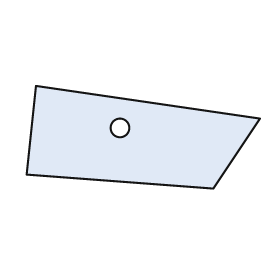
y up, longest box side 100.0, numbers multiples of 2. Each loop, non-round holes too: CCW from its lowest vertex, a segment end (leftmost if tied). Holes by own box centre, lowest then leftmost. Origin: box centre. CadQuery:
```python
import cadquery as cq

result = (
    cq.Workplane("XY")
    .moveTo(30.0, -22.0)
    .lineTo(50.0, 8.0)
    .lineTo(-46.0, 22.0)
    .lineTo(-50.0, -16.0)
    .close()
    .moveTo(-10.0, 4.0)
    .circle(4.0)
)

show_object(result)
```